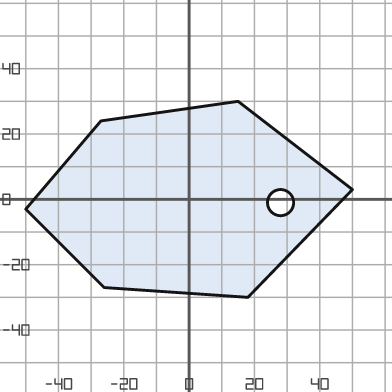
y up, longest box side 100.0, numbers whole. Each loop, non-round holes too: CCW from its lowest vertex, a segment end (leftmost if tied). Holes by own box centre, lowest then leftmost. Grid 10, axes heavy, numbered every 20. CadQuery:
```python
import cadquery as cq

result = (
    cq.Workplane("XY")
    .moveTo(18.0, -30.0)
    .lineTo(50.0, 3.0)
    .lineTo(15.0, 30.0)
    .lineTo(-27.0, 24.0)
    .lineTo(-50.0, -3.0)
    .lineTo(-26.0, -27.0)
    .close()
    .moveTo(28.0, -1.0)
    .circle(4.0)
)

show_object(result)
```